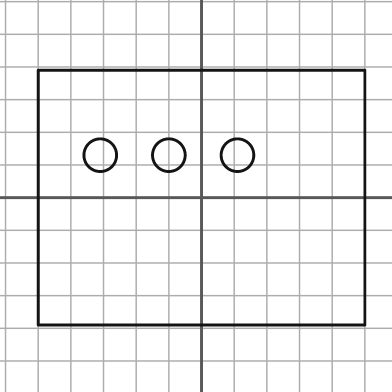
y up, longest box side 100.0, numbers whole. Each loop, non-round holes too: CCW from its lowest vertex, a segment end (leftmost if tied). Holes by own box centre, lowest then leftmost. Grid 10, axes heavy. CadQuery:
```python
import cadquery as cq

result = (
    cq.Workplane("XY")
    .moveTo(-50.0, -39.0)
    .lineTo(50.0, -39.0)
    .lineTo(50.0, 39.0)
    .lineTo(-50.0, 39.0)
    .close()
    .moveTo(-31.0, 13.0)
    .circle(5.0)
    .moveTo(-10.0, 13.0)
    .circle(5.0)
    .moveTo(11.0, 13.0)
    .circle(5.0)
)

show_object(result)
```